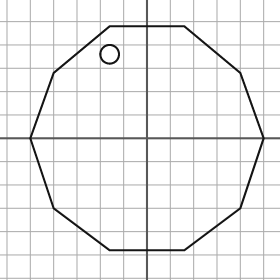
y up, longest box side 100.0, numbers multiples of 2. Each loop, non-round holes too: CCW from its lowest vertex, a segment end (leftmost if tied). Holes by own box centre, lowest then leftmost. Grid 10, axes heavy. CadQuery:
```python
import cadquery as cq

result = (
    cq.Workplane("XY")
    .moveTo(-16.0, -48.0)
    .lineTo(16.0, -48.0)
    .lineTo(40.0, -30.0)
    .lineTo(50.0, 0.0)
    .lineTo(40.0, 28.0)
    .lineTo(16.0, 48.0)
    .lineTo(-16.0, 48.0)
    .lineTo(-40.0, 28.0)
    .lineTo(-50.0, 0.0)
    .lineTo(-40.0, -30.0)
    .close()
    .moveTo(-16.0, 36.0)
    .circle(4.0)
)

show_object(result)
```